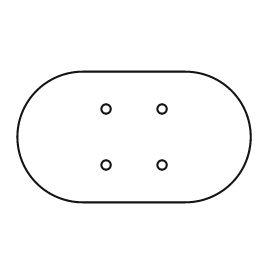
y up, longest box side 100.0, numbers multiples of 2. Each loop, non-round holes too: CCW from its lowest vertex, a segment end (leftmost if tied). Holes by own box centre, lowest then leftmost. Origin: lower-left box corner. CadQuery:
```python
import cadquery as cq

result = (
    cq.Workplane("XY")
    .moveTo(28.0, 0.0)
    .lineTo(72.0, 0.0)
    .threePointArc((100.0, 28.0), (72.0, 56.0))
    .lineTo(28.0, 56.0)
    .threePointArc((0.0, 28.0), (28.0, 0.0))
    .close()
    .moveTo(38.0, 16.0)
    .circle(2.0)
    .moveTo(62.0, 16.0)
    .circle(2.0)
    .moveTo(38.0, 40.0)
    .circle(2.0)
    .moveTo(62.0, 40.0)
    .circle(2.0)
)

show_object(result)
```